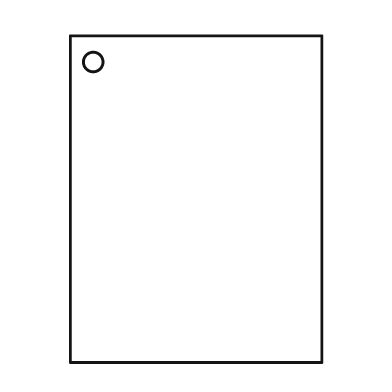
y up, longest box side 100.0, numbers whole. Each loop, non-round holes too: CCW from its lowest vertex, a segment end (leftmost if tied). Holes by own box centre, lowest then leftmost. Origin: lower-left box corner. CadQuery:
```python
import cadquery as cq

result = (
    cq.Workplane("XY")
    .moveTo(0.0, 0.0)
    .lineTo(77.0, 0.0)
    .lineTo(77.0, 100.0)
    .lineTo(0.0, 100.0)
    .close()
    .moveTo(7.0, 92.0)
    .circle(3.0)
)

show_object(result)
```